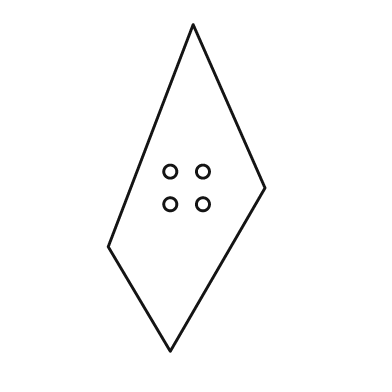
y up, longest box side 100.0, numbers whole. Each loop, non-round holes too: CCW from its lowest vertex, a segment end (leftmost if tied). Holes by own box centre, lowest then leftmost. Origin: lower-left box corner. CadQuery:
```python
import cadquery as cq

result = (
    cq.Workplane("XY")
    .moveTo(19.0, 0.0)
    .lineTo(48.0, 50.0)
    .lineTo(26.0, 100.0)
    .lineTo(0.0, 32.0)
    .close()
    .moveTo(19.0, 45.0)
    .circle(2.0)
    .moveTo(29.0, 45.0)
    .circle(2.0)
    .moveTo(19.0, 55.0)
    .circle(2.0)
    .moveTo(29.0, 55.0)
    .circle(2.0)
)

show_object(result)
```